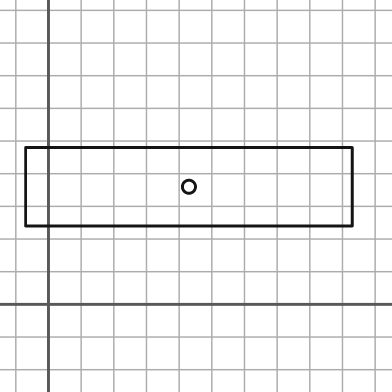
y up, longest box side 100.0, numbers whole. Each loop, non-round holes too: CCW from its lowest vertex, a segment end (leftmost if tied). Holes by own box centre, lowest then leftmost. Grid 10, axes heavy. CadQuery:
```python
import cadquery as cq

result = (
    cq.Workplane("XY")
    .moveTo(-7.0, 24.0)
    .lineTo(93.0, 24.0)
    .lineTo(93.0, 48.0)
    .lineTo(-7.0, 48.0)
    .close()
    .moveTo(43.0, 36.0)
    .circle(2.0)
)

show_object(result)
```